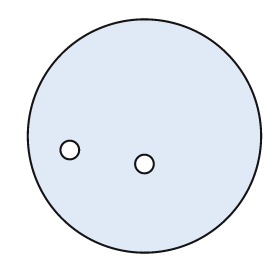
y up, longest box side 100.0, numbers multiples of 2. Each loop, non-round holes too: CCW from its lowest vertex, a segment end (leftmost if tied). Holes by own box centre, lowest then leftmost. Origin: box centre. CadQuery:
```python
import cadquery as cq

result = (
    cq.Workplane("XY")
    .moveTo(0.0, 0.0)
    .circle(50.0)
    .moveTo(0.0, -12.0)
    .circle(4.0)
    .moveTo(-32.0, -6.0)
    .circle(4.0)
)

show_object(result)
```